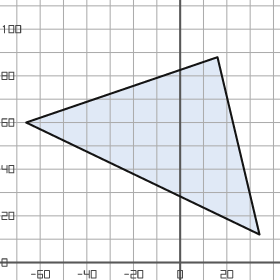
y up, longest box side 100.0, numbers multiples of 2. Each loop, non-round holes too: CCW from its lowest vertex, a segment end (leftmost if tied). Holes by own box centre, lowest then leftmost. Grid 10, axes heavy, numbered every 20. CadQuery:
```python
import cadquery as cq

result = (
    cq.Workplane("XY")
    .moveTo(34.0, 12.0)
    .lineTo(16.0, 88.0)
    .lineTo(-66.0, 60.0)
    .close()
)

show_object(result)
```